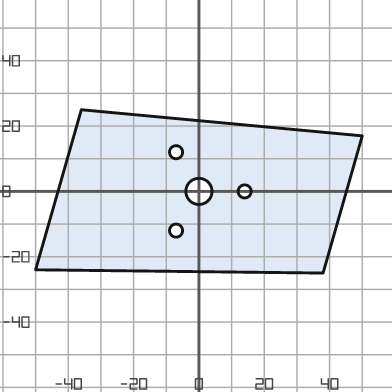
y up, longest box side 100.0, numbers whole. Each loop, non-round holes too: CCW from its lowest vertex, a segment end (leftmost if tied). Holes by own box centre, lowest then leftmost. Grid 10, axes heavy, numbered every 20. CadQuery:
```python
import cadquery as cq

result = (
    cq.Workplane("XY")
    .moveTo(38.0, -25.0)
    .lineTo(50.0, 17.0)
    .lineTo(-36.0, 25.0)
    .lineTo(-50.0, -24.0)
    .close()
    .moveTo(-7.0, -12.0)
    .circle(2.0)
    .moveTo(0.0, 0.0)
    .circle(4.0)
    .moveTo(14.0, 0.0)
    .circle(2.0)
    .moveTo(-7.0, 12.0)
    .circle(2.0)
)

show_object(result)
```